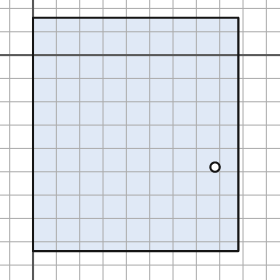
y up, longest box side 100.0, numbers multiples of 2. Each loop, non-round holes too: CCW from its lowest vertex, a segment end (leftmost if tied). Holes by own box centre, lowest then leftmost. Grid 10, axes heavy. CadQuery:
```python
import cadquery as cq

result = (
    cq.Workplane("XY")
    .moveTo(0.0, -84.0)
    .lineTo(88.0, -84.0)
    .lineTo(88.0, 16.0)
    .lineTo(0.0, 16.0)
    .close()
    .moveTo(78.0, -48.0)
    .circle(2.0)
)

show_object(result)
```